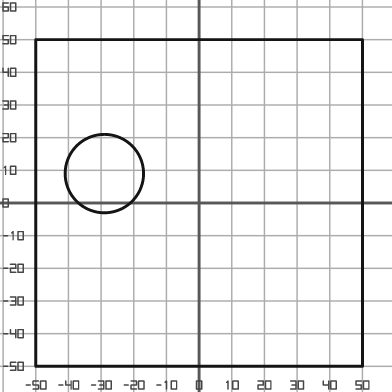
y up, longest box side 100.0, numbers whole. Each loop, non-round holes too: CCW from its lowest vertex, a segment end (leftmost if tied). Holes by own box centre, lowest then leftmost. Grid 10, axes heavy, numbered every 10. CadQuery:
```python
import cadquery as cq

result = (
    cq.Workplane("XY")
    .moveTo(-50.0, -50.0)
    .lineTo(50.0, -50.0)
    .lineTo(50.0, 50.0)
    .lineTo(-50.0, 50.0)
    .close()
    .moveTo(-29.0, 9.0)
    .circle(12.0)
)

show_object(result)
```